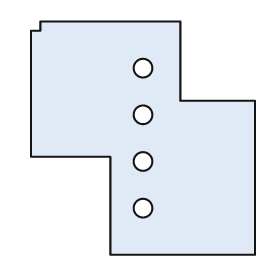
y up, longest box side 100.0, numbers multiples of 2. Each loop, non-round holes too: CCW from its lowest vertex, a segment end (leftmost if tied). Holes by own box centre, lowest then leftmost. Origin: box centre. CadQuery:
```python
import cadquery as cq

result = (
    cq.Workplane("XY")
    .moveTo(-14.0, -50.0)
    .lineTo(48.0, -50.0)
    .lineTo(48.0, 16.0)
    .lineTo(16.0, 16.0)
    .lineTo(16.0, 50.0)
    .lineTo(-44.0, 50.0)
    .lineTo(-44.0, 46.0)
    .lineTo(-48.0, 46.0)
    .lineTo(-48.0, -8.0)
    .lineTo(-14.0, -8.0)
    .close()
    .moveTo(0.0, -30.0)
    .circle(4.0)
    .moveTo(0.0, -10.0)
    .circle(4.0)
    .moveTo(0.0, 10.0)
    .circle(4.0)
    .moveTo(0.0, 30.0)
    .circle(4.0)
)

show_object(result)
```